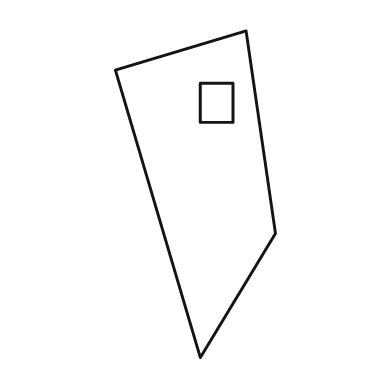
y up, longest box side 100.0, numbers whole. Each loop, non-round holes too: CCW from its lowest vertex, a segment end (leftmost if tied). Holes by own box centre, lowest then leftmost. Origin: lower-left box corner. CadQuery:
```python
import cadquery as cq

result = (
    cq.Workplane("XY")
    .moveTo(26.0, 0.0)
    .lineTo(49.0, 38.0)
    .lineTo(40.0, 100.0)
    .lineTo(0.0, 88.0)
    .close()
    .moveTo(26.0, 72.0)
    .lineTo(36.0, 72.0)
    .lineTo(36.0, 84.0)
    .lineTo(26.0, 84.0)
    .close()
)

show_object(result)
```